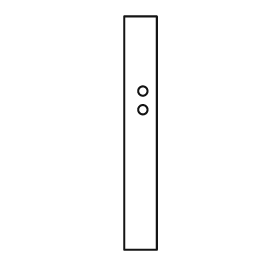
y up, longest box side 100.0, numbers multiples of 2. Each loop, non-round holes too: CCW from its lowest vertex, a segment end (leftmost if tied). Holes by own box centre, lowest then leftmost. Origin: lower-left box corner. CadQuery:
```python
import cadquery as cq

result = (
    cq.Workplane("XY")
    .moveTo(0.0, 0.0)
    .lineTo(14.0, 0.0)
    .lineTo(14.0, 100.0)
    .lineTo(0.0, 100.0)
    .close()
    .moveTo(8.0, 60.0)
    .circle(2.0)
    .moveTo(8.0, 68.0)
    .circle(2.0)
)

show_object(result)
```